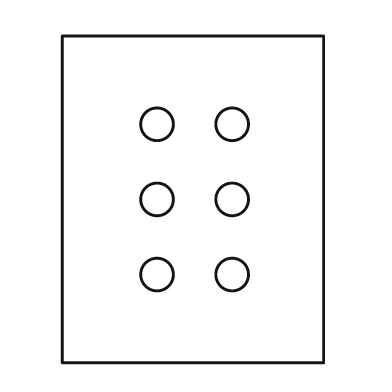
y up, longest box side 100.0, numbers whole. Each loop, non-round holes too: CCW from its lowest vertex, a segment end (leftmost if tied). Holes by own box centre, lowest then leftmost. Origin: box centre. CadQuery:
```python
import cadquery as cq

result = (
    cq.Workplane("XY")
    .moveTo(-40.0, -50.0)
    .lineTo(40.0, -50.0)
    .lineTo(40.0, 50.0)
    .lineTo(-40.0, 50.0)
    .close()
    .moveTo(-11.0, -23.0)
    .circle(5.0)
    .moveTo(12.0, -23.0)
    .circle(5.0)
    .moveTo(-11.0, 0.0)
    .circle(5.0)
    .moveTo(12.0, 0.0)
    .circle(5.0)
    .moveTo(-11.0, 23.0)
    .circle(5.0)
    .moveTo(12.0, 23.0)
    .circle(5.0)
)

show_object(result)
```